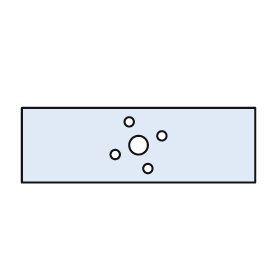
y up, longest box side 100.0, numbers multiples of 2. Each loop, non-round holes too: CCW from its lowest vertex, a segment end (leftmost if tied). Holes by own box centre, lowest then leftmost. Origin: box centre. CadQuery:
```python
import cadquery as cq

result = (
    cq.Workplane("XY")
    .moveTo(-50.0, -16.0)
    .lineTo(50.0, -16.0)
    .lineTo(50.0, 16.0)
    .lineTo(-50.0, 16.0)
    .close()
    .moveTo(4.0, -10.0)
    .circle(2.0)
    .moveTo(-10.0, -4.0)
    .circle(2.0)
    .moveTo(0.0, 0.0)
    .circle(4.0)
    .moveTo(10.0, 4.0)
    .circle(2.0)
    .moveTo(-4.0, 10.0)
    .circle(2.0)
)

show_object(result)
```